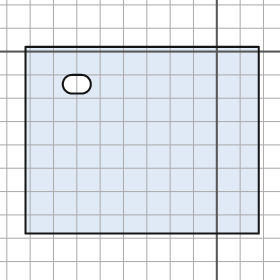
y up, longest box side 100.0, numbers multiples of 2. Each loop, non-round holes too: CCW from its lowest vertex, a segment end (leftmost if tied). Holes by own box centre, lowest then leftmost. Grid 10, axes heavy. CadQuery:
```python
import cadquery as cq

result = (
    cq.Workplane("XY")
    .moveTo(-82.0, -78.0)
    .lineTo(18.0, -78.0)
    .lineTo(18.0, 2.0)
    .lineTo(-82.0, 2.0)
    .close()
    .moveTo(-62.0, -18.0)
    .lineTo(-58.0, -18.0)
    .threePointArc((-54.0, -14.0), (-58.0, -10.0))
    .lineTo(-62.0, -10.0)
    .threePointArc((-66.0, -14.0), (-62.0, -18.0))
    .close()
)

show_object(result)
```